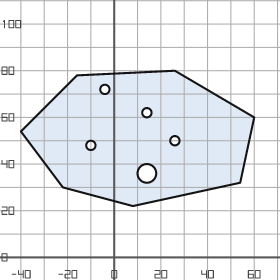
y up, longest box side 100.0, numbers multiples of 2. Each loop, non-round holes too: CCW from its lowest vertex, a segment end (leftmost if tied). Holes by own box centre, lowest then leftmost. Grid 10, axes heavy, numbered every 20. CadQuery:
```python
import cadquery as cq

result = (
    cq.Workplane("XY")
    .moveTo(8.0, 22.0)
    .lineTo(54.0, 32.0)
    .lineTo(60.0, 60.0)
    .lineTo(26.0, 80.0)
    .lineTo(-16.0, 78.0)
    .lineTo(-40.0, 54.0)
    .lineTo(-22.0, 30.0)
    .close()
    .moveTo(14.0, 36.0)
    .circle(4.0)
    .moveTo(-10.0, 48.0)
    .circle(2.0)
    .moveTo(26.0, 50.0)
    .circle(2.0)
    .moveTo(14.0, 62.0)
    .circle(2.0)
    .moveTo(-4.0, 72.0)
    .circle(2.0)
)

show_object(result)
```